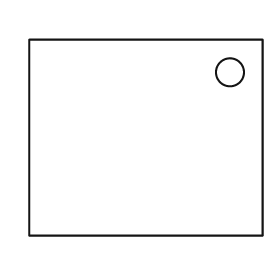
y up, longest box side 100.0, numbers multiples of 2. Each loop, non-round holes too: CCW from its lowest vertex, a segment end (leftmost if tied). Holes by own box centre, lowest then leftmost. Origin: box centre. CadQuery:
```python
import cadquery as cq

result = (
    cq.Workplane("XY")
    .moveTo(-50.0, -42.0)
    .lineTo(50.0, -42.0)
    .lineTo(50.0, 42.0)
    .lineTo(-50.0, 42.0)
    .close()
    .moveTo(36.0, 28.0)
    .circle(6.0)
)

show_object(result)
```